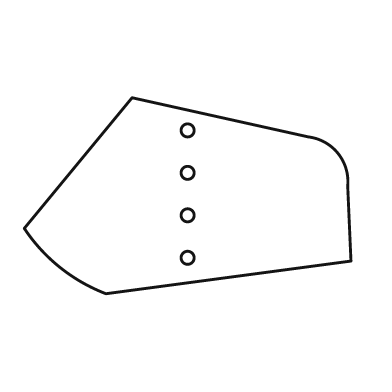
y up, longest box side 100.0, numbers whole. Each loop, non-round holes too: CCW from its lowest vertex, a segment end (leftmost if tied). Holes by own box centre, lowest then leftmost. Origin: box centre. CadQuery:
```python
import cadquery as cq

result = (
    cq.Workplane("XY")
    .moveTo(-25.0, -30.0)
    .lineTo(50.0, -20.0)
    .lineTo(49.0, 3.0)
    .threePointArc((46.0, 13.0), (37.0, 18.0))
    .lineTo(-17.0, 30.0)
    .lineTo(-50.0, -10.0)
    .threePointArc((-39.0, -22.0), (-25.0, -30.0))
    .close()
    .moveTo(0.0, -19.0)
    .circle(2.0)
    .moveTo(0.0, -6.0)
    .circle(2.0)
    .moveTo(0.0, 7.0)
    .circle(2.0)
    .moveTo(0.0, 20.0)
    .circle(2.0)
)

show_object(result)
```